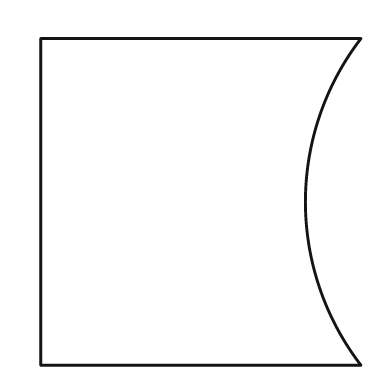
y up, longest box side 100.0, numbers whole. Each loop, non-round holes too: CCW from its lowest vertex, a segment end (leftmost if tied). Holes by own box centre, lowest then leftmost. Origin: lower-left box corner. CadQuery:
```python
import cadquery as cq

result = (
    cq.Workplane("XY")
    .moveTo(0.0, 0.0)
    .lineTo(98.0, 0.0)
    .threePointArc((81.0, 50.0), (98.0, 100.0))
    .lineTo(0.0, 100.0)
    .close()
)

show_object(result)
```